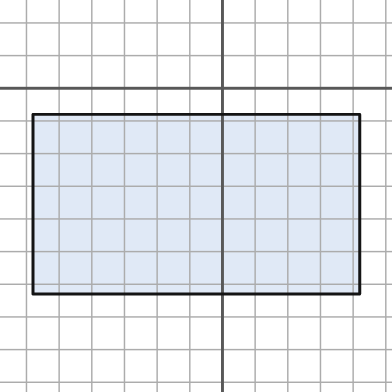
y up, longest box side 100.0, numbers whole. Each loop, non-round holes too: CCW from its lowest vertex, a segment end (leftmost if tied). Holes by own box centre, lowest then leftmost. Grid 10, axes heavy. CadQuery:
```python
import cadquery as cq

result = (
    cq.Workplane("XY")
    .moveTo(-58.0, -63.0)
    .lineTo(42.0, -63.0)
    .lineTo(42.0, -8.0)
    .lineTo(-58.0, -8.0)
    .close()
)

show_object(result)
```